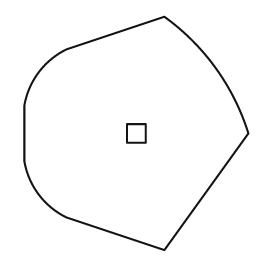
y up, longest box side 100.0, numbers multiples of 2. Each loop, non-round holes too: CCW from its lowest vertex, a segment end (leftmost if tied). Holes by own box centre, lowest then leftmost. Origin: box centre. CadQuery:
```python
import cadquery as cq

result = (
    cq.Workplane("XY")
    .moveTo(12.0, -50.0)
    .lineTo(48.0, 0.0)
    .threePointArc((34.0, 28.0), (12.0, 50.0))
    .lineTo(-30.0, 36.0)
    .threePointArc((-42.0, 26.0), (-48.0, 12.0))
    .lineTo(-48.0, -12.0)
    .threePointArc((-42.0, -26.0), (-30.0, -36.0))
    .close()
    .moveTo(-4.0, -4.0)
    .lineTo(4.0, -4.0)
    .lineTo(4.0, 4.0)
    .lineTo(-4.0, 4.0)
    .close()
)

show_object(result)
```